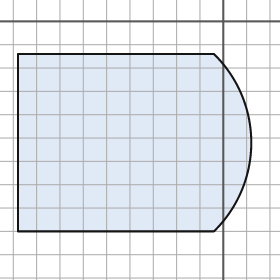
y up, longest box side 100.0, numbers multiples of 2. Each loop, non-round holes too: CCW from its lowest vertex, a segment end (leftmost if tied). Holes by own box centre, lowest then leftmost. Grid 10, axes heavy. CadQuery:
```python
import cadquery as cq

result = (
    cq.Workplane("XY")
    .moveTo(-88.0, -90.0)
    .lineTo(-4.0, -90.0)
    .threePointArc((12.0, -52.0), (-4.0, -14.0))
    .lineTo(-88.0, -14.0)
    .close()
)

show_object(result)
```